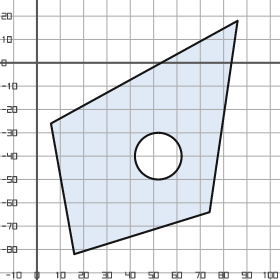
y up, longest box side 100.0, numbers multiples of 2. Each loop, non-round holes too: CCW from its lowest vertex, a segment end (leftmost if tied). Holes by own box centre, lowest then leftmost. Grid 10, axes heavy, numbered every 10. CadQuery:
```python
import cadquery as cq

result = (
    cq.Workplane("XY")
    .moveTo(16.0, -82.0)
    .lineTo(74.0, -64.0)
    .lineTo(86.0, 18.0)
    .lineTo(6.0, -26.0)
    .close()
    .moveTo(52.0, -40.0)
    .circle(10.0)
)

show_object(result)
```